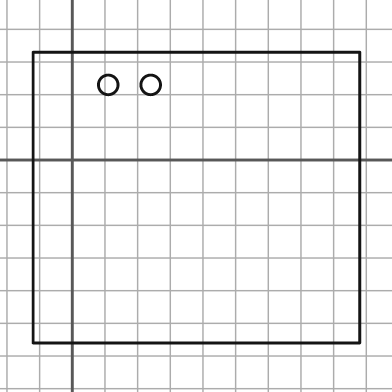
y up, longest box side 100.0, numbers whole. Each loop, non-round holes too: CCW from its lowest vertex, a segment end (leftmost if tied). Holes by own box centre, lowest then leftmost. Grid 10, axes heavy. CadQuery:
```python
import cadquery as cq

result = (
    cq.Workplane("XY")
    .moveTo(-12.0, -56.0)
    .lineTo(88.0, -56.0)
    .lineTo(88.0, 33.0)
    .lineTo(-12.0, 33.0)
    .close()
    .moveTo(11.0, 23.0)
    .circle(3.0)
    .moveTo(24.0, 23.0)
    .circle(3.0)
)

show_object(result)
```